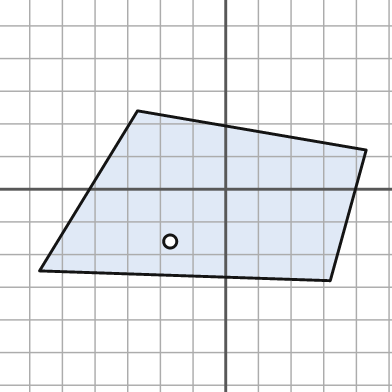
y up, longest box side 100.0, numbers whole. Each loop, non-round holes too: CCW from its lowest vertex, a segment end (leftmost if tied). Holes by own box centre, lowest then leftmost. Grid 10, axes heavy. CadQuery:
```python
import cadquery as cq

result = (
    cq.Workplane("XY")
    .moveTo(32.0, -28.0)
    .lineTo(43.0, 12.0)
    .lineTo(-27.0, 24.0)
    .lineTo(-57.0, -25.0)
    .close()
    .moveTo(-17.0, -16.0)
    .circle(2.0)
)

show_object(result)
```